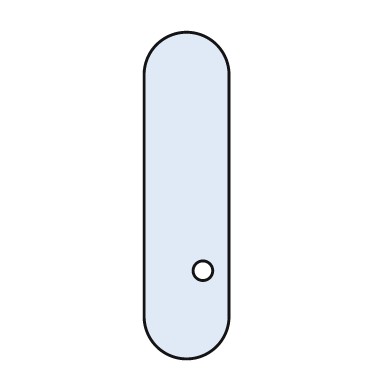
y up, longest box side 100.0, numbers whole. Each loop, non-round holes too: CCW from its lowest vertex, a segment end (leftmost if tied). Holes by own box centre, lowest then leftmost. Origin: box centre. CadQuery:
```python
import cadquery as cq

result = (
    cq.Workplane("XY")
    .moveTo(-13.0, -37.0)
    .threePointArc((0.0, -50.0), (13.0, -37.0))
    .lineTo(13.0, 37.0)
    .threePointArc((0.0, 50.0), (-13.0, 37.0))
    .close()
    .moveTo(5.0, -23.0)
    .circle(3.0)
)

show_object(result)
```